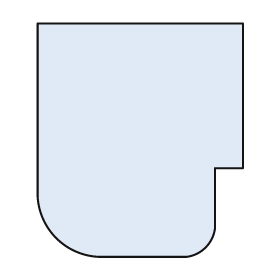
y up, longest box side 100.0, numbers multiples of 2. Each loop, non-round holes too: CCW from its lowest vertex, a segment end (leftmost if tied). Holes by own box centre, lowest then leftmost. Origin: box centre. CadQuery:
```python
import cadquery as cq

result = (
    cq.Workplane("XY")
    .moveTo(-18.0, -50.0)
    .lineTo(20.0, -50.0)
    .threePointArc((28.0, -46.0), (32.0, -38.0))
    .lineTo(32.0, -12.0)
    .lineTo(44.0, -12.0)
    .lineTo(44.0, 50.0)
    .lineTo(-44.0, 50.0)
    .lineTo(-44.0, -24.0)
    .threePointArc((-36.0, -42.0), (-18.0, -50.0))
    .close()
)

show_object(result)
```